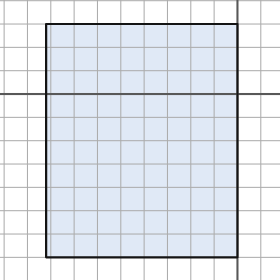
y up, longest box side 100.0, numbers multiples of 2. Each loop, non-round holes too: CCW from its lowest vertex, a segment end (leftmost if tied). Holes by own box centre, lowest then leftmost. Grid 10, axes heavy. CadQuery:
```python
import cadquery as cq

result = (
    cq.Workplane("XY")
    .moveTo(-82.0, -70.0)
    .lineTo(0.0, -70.0)
    .lineTo(0.0, 30.0)
    .lineTo(-82.0, 30.0)
    .close()
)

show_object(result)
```